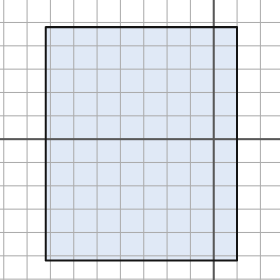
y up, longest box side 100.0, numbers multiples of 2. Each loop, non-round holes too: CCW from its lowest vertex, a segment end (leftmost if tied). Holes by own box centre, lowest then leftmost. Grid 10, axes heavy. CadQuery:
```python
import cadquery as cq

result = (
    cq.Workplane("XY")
    .moveTo(-72.0, -52.0)
    .lineTo(10.0, -52.0)
    .lineTo(10.0, 48.0)
    .lineTo(-72.0, 48.0)
    .close()
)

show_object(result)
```